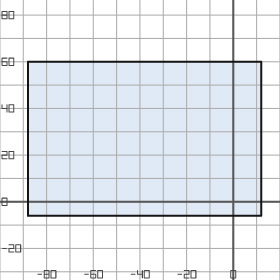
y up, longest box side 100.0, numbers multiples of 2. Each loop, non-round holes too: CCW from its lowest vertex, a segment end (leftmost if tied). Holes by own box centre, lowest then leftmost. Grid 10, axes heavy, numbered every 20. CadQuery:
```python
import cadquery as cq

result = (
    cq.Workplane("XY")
    .moveTo(-88.0, -6.0)
    .lineTo(12.0, -6.0)
    .lineTo(12.0, 60.0)
    .lineTo(-88.0, 60.0)
    .close()
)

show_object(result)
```